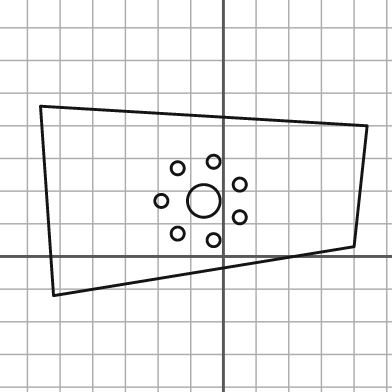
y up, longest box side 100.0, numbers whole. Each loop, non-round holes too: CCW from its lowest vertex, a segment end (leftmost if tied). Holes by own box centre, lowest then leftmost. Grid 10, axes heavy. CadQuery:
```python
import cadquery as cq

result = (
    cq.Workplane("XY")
    .moveTo(-52.0, -12.0)
    .lineTo(40.0, 3.0)
    .lineTo(44.0, 40.0)
    .lineTo(-56.0, 46.0)
    .close()
    .moveTo(-3.0, 5.0)
    .circle(2.0)
    .moveTo(-14.0, 7.0)
    .circle(2.0)
    .moveTo(5.0, 12.0)
    .circle(2.0)
    .moveTo(-19.0, 17.0)
    .circle(2.0)
    .moveTo(-6.0, 17.0)
    .circle(5.0)
    .moveTo(5.0, 22.0)
    .circle(2.0)
    .moveTo(-14.0, 27.0)
    .circle(2.0)
    .moveTo(-3.0, 29.0)
    .circle(2.0)
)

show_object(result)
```